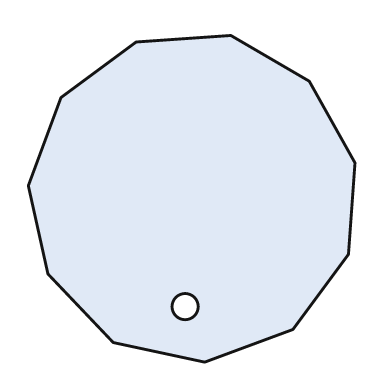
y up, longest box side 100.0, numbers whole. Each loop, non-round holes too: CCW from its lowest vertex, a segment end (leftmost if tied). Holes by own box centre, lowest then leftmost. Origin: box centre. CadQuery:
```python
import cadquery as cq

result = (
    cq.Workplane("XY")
    .moveTo(4.0, -50.0)
    .lineTo(31.0, -40.0)
    .lineTo(48.0, -17.0)
    .lineTo(50.0, 11.0)
    .lineTo(36.0, 36.0)
    .lineTo(12.0, 50.0)
    .lineTo(-17.0, 48.0)
    .lineTo(-40.0, 31.0)
    .lineTo(-50.0, 4.0)
    .lineTo(-44.0, -23.0)
    .lineTo(-24.0, -44.0)
    .close()
    .moveTo(-2.0, -33.0)
    .circle(4.0)
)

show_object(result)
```